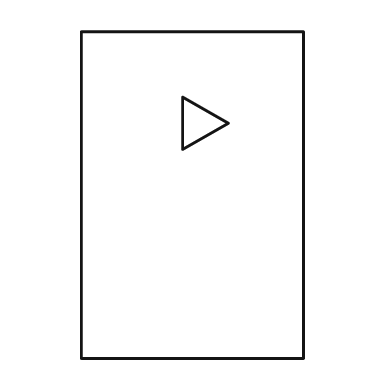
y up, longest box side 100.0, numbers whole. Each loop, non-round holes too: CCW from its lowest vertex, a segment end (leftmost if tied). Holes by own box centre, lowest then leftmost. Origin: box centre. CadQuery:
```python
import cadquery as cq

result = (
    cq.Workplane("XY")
    .moveTo(-34.0, -50.0)
    .lineTo(34.0, -50.0)
    .lineTo(34.0, 50.0)
    .lineTo(-34.0, 50.0)
    .close()
    .moveTo(-3.0, 14.0)
    .lineTo(11.0, 22.0)
    .lineTo(-3.0, 30.0)
    .close()
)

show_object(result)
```